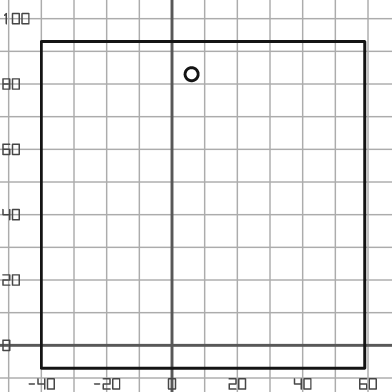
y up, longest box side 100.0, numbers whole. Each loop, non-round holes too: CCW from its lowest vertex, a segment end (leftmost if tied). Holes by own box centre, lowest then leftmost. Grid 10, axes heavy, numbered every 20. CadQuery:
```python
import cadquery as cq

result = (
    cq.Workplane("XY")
    .moveTo(-40.0, -7.0)
    .lineTo(59.0, -7.0)
    .lineTo(59.0, 93.0)
    .lineTo(-40.0, 93.0)
    .close()
    .moveTo(6.0, 83.0)
    .circle(2.0)
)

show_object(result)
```